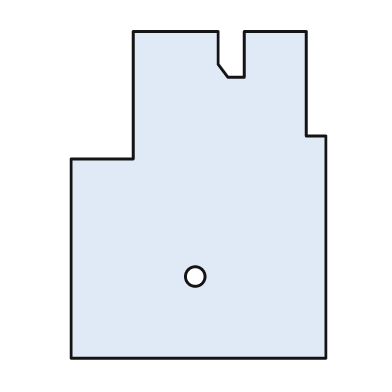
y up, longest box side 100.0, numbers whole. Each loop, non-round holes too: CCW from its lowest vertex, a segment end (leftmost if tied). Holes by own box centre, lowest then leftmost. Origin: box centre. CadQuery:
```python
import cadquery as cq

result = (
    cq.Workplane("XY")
    .moveTo(-39.0, -50.0)
    .lineTo(39.0, -50.0)
    .lineTo(39.0, 18.0)
    .lineTo(33.0, 18.0)
    .lineTo(33.0, 50.0)
    .lineTo(14.0, 50.0)
    .lineTo(14.0, 36.0)
    .lineTo(9.0, 36.0)
    .lineTo(6.0, 40.0)
    .lineTo(6.0, 50.0)
    .lineTo(-20.0, 50.0)
    .lineTo(-20.0, 11.0)
    .lineTo(-39.0, 11.0)
    .close()
    .moveTo(-1.0, -25.0)
    .circle(3.0)
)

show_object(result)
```